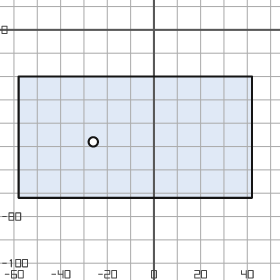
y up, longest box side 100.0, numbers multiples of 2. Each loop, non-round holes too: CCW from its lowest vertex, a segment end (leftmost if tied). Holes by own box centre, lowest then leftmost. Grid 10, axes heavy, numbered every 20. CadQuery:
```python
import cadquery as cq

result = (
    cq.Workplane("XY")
    .moveTo(-58.0, -72.0)
    .lineTo(42.0, -72.0)
    .lineTo(42.0, -20.0)
    .lineTo(-58.0, -20.0)
    .close()
    .moveTo(-26.0, -48.0)
    .circle(2.0)
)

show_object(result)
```